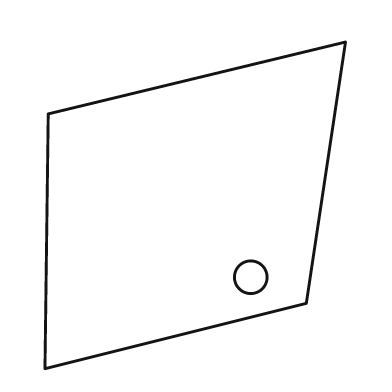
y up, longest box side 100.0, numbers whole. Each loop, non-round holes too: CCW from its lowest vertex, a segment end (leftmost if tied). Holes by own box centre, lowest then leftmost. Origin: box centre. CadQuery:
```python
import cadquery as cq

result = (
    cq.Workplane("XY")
    .moveTo(-46.0, -50.0)
    .lineTo(34.0, -30.0)
    .lineTo(46.0, 50.0)
    .lineTo(-45.0, 28.0)
    .close()
    .moveTo(17.0, -22.0)
    .circle(5.0)
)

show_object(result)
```